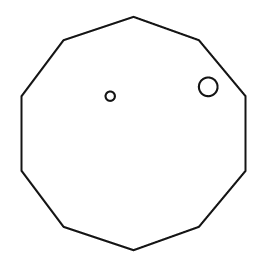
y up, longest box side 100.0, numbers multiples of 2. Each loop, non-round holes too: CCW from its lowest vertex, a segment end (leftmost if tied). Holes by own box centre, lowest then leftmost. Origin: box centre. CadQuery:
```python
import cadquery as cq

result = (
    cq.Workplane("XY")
    .moveTo(0.0, -50.0)
    .lineTo(28.0, -40.0)
    .lineTo(48.0, -16.0)
    .lineTo(48.0, 16.0)
    .lineTo(28.0, 40.0)
    .lineTo(0.0, 50.0)
    .lineTo(-30.0, 40.0)
    .lineTo(-48.0, 16.0)
    .lineTo(-48.0, -16.0)
    .lineTo(-30.0, -40.0)
    .close()
    .moveTo(-10.0, 16.0)
    .circle(2.0)
    .moveTo(32.0, 20.0)
    .circle(4.0)
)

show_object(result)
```